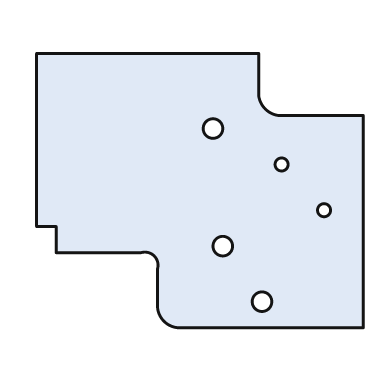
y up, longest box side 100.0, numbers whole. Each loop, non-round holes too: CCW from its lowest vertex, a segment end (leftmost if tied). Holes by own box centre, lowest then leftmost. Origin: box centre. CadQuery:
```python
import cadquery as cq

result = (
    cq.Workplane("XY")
    .moveTo(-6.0, -42.0)
    .lineTo(50.0, -42.0)
    .lineTo(50.0, 23.0)
    .lineTo(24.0, 23.0)
    .threePointArc((20.0, 25.0), (18.0, 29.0))
    .lineTo(18.0, 42.0)
    .lineTo(-50.0, 42.0)
    .lineTo(-50.0, -11.0)
    .lineTo(-44.0, -11.0)
    .lineTo(-44.0, -19.0)
    .lineTo(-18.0, -19.0)
    .threePointArc((-14.0, -20.0), (-13.0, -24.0))
    .lineTo(-13.0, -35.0)
    .threePointArc((-11.0, -40.0), (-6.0, -42.0))
    .close()
    .moveTo(19.0, -34.0)
    .circle(3.0)
    .moveTo(7.0, -17.0)
    .circle(3.0)
    .moveTo(38.0, -6.0)
    .circle(2.0)
    .moveTo(25.0, 8.0)
    .circle(2.0)
    .moveTo(4.0, 19.0)
    .circle(3.0)
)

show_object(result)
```